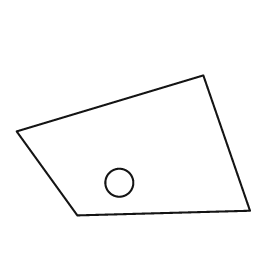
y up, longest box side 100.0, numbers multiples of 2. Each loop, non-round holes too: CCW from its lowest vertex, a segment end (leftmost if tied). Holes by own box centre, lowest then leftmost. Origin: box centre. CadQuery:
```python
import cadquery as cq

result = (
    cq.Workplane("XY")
    .moveTo(-24.0, -30.0)
    .lineTo(50.0, -28.0)
    .lineTo(30.0, 30.0)
    .lineTo(-50.0, 6.0)
    .close()
    .moveTo(-6.0, -16.0)
    .circle(6.0)
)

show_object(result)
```